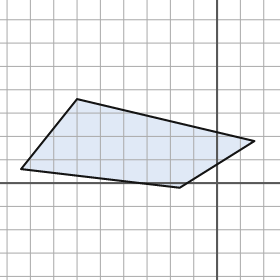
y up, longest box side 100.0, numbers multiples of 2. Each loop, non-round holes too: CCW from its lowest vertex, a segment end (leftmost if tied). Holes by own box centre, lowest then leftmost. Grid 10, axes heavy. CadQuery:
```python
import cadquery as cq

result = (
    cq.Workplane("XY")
    .moveTo(-16.0, -2.0)
    .lineTo(16.0, 18.0)
    .lineTo(-60.0, 36.0)
    .lineTo(-84.0, 6.0)
    .close()
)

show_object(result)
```